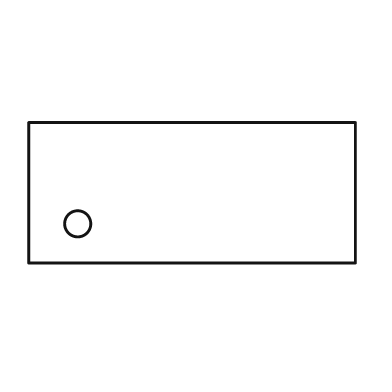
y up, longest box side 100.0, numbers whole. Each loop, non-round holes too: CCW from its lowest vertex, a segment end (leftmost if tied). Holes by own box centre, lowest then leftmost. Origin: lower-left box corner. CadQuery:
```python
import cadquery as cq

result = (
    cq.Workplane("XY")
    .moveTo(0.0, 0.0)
    .lineTo(100.0, 0.0)
    .lineTo(100.0, 43.0)
    .lineTo(0.0, 43.0)
    .close()
    .moveTo(15.0, 12.0)
    .circle(4.0)
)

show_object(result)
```